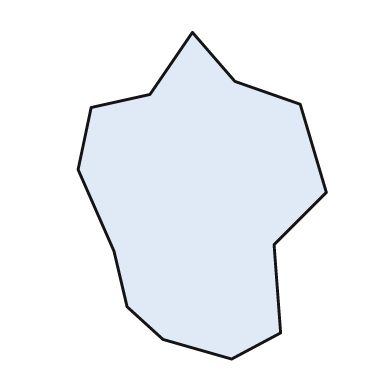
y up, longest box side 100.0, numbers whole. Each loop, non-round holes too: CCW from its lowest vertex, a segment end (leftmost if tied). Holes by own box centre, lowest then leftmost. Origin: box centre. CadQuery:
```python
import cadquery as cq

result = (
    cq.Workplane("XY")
    .moveTo(9.0, -50.0)
    .lineTo(24.0, -42.0)
    .lineTo(22.0, -15.0)
    .lineTo(38.0, 1.0)
    .lineTo(30.0, 28.0)
    .lineTo(10.0, 35.0)
    .lineTo(-3.0, 50.0)
    .lineTo(-16.0, 31.0)
    .lineTo(-34.0, 27.0)
    .lineTo(-38.0, 8.0)
    .lineTo(-27.0, -17.0)
    .lineTo(-23.0, -34.0)
    .lineTo(-12.0, -44.0)
    .close()
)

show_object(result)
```